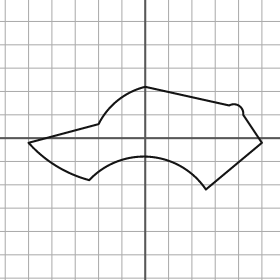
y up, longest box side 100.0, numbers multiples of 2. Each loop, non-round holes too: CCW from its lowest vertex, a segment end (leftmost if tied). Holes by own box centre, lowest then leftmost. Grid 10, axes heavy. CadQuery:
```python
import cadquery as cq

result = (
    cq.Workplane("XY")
    .moveTo(26.0, -22.0)
    .lineTo(50.0, -2.0)
    .lineTo(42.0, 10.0)
    .threePointArc((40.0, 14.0), (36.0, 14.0))
    .lineTo(0.0, 22.0)
    .threePointArc((-12.0, 16.0), (-20.0, 6.0))
    .lineTo(-50.0, -2.0)
    .threePointArc((-38.0, -12.0), (-24.0, -18.0))
    .threePointArc((2.0, -8.0), (26.0, -22.0))
    .close()
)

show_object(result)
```